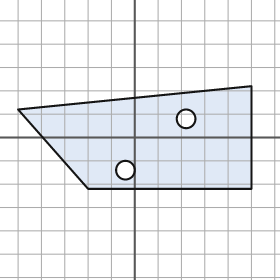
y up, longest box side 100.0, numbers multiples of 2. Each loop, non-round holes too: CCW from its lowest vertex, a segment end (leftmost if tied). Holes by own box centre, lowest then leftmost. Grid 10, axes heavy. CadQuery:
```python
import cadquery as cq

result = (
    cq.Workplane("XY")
    .moveTo(-20.0, -22.0)
    .lineTo(50.0, -22.0)
    .lineTo(50.0, 22.0)
    .lineTo(-50.0, 12.0)
    .close()
    .moveTo(-4.0, -14.0)
    .circle(4.0)
    .moveTo(22.0, 8.0)
    .circle(4.0)
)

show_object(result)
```